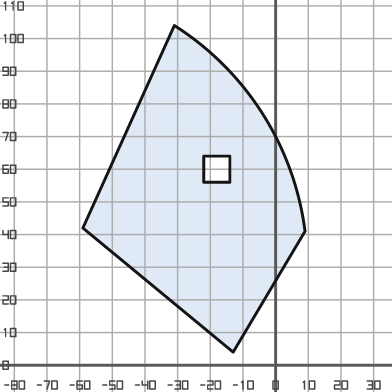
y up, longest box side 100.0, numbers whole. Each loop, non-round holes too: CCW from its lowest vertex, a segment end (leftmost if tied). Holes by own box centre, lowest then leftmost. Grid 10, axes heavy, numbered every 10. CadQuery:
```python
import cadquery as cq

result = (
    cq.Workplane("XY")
    .moveTo(-13.0, 4.0)
    .lineTo(9.0, 41.0)
    .threePointArc((-4.0, 77.0), (-31.0, 104.0))
    .lineTo(-59.0, 42.0)
    .close()
    .moveTo(-22.0, 56.0)
    .lineTo(-14.0, 56.0)
    .lineTo(-14.0, 64.0)
    .lineTo(-22.0, 64.0)
    .close()
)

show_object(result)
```